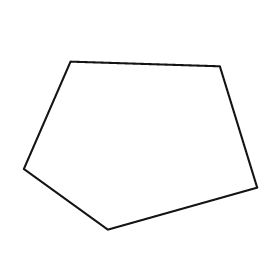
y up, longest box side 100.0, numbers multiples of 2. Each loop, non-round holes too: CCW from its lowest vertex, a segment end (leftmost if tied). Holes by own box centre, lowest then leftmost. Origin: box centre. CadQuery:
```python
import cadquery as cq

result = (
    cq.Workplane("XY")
    .moveTo(-14.0, -36.0)
    .lineTo(50.0, -18.0)
    .lineTo(34.0, 34.0)
    .lineTo(-30.0, 36.0)
    .lineTo(-50.0, -10.0)
    .close()
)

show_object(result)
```